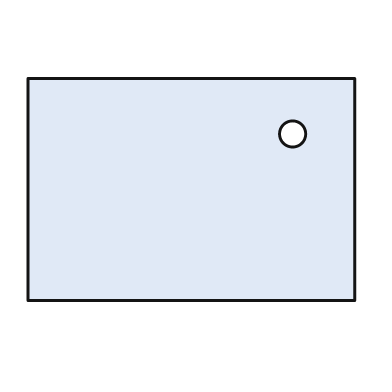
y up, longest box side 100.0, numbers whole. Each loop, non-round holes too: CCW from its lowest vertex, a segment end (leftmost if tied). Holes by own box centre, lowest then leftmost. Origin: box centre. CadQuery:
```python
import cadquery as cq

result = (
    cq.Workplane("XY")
    .moveTo(-50.0, -34.0)
    .lineTo(50.0, -34.0)
    .lineTo(50.0, 34.0)
    .lineTo(-50.0, 34.0)
    .close()
    .moveTo(31.0, 17.0)
    .circle(4.0)
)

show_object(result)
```